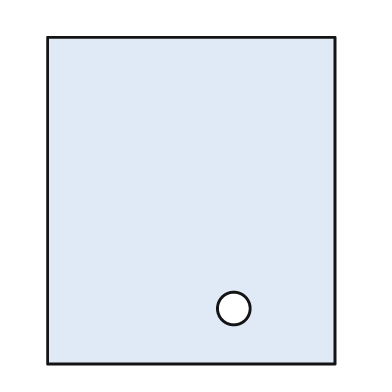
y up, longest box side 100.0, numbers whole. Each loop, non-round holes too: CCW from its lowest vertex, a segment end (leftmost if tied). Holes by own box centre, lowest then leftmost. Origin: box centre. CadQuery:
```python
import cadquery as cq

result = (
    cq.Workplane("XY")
    .moveTo(-44.0, -50.0)
    .lineTo(44.0, -50.0)
    .lineTo(44.0, 50.0)
    .lineTo(-44.0, 50.0)
    .close()
    .moveTo(13.0, -33.0)
    .circle(5.0)
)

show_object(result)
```